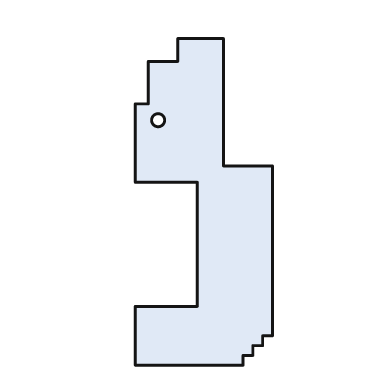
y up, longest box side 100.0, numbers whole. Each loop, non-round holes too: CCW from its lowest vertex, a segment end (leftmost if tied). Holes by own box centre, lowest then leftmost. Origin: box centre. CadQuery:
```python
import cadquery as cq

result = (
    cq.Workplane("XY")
    .moveTo(-21.0, -50.0)
    .lineTo(12.0, -50.0)
    .lineTo(12.0, -47.0)
    .lineTo(15.0, -47.0)
    .lineTo(15.0, -44.0)
    .lineTo(18.0, -44.0)
    .lineTo(18.0, -41.0)
    .lineTo(21.0, -41.0)
    .lineTo(21.0, 11.0)
    .lineTo(6.0, 11.0)
    .lineTo(6.0, 50.0)
    .lineTo(-8.0, 50.0)
    .lineTo(-8.0, 43.0)
    .lineTo(-17.0, 43.0)
    .lineTo(-17.0, 30.0)
    .lineTo(-21.0, 30.0)
    .lineTo(-21.0, 6.0)
    .lineTo(-2.0, 6.0)
    .lineTo(-2.0, -32.0)
    .lineTo(-21.0, -32.0)
    .close()
    .moveTo(-14.0, 25.0)
    .circle(2.0)
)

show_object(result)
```